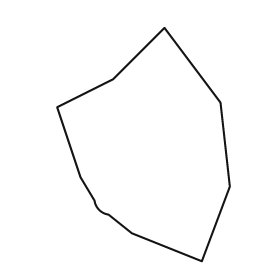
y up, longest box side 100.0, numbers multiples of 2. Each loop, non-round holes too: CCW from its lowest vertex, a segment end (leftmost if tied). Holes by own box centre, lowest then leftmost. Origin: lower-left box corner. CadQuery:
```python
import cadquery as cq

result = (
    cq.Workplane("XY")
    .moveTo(62.0, 0.0)
    .lineTo(74.0, 32.0)
    .lineTo(70.0, 68.0)
    .lineTo(46.0, 100.0)
    .lineTo(24.0, 78.0)
    .lineTo(0.0, 66.0)
    .lineTo(10.0, 36.0)
    .lineTo(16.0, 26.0)
    .threePointArc((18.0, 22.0), (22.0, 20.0))
    .lineTo(32.0, 12.0)
    .close()
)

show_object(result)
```